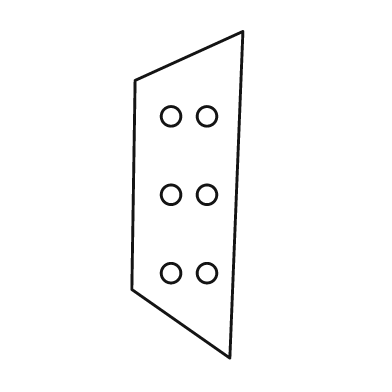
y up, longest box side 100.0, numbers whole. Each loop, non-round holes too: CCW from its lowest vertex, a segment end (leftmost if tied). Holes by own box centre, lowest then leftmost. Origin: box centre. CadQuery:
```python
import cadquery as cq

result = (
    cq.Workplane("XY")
    .moveTo(13.0, -50.0)
    .lineTo(17.0, 50.0)
    .lineTo(-16.0, 35.0)
    .lineTo(-17.0, -29.0)
    .close()
    .moveTo(-5.0, -24.0)
    .circle(3.0)
    .moveTo(6.0, -24.0)
    .circle(3.0)
    .moveTo(-5.0, 0.0)
    .circle(3.0)
    .moveTo(6.0, 0.0)
    .circle(3.0)
    .moveTo(-5.0, 24.0)
    .circle(3.0)
    .moveTo(6.0, 24.0)
    .circle(3.0)
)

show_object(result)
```